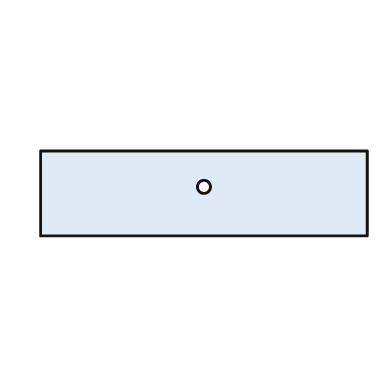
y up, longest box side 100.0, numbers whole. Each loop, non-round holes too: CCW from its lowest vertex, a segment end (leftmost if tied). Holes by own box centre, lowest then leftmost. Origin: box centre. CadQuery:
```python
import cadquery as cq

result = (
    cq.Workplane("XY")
    .moveTo(-50.0, -13.0)
    .lineTo(50.0, -13.0)
    .lineTo(50.0, 13.0)
    .lineTo(-50.0, 13.0)
    .close()
    .moveTo(0.0, 2.0)
    .circle(2.0)
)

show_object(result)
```